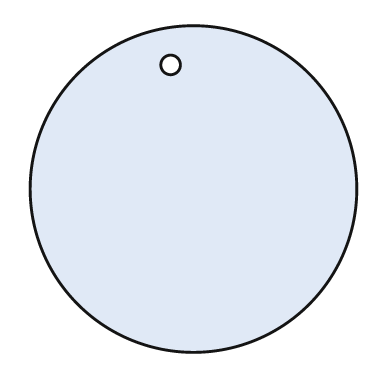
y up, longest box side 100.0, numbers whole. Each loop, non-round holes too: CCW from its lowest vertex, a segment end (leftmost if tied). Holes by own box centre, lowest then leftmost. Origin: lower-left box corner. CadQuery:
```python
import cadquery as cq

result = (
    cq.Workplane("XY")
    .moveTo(50.0, 50.0)
    .circle(50.0)
    .moveTo(43.0, 88.0)
    .circle(3.0)
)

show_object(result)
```